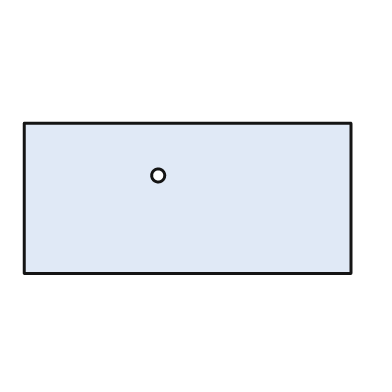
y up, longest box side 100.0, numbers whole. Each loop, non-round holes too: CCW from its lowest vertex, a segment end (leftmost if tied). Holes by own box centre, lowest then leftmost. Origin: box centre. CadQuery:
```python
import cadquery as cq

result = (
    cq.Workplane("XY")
    .moveTo(-50.0, -23.0)
    .lineTo(50.0, -23.0)
    .lineTo(50.0, 23.0)
    .lineTo(-50.0, 23.0)
    .close()
    .moveTo(-9.0, 7.0)
    .circle(2.0)
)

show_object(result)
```